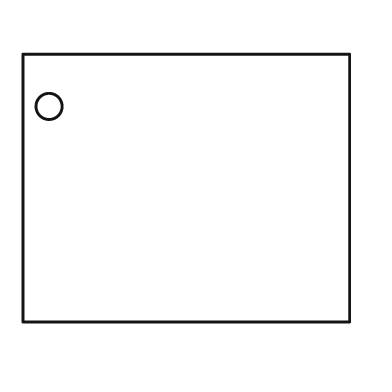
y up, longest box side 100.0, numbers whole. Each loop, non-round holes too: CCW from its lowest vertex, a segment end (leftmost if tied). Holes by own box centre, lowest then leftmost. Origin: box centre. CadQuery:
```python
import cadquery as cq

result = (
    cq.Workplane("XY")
    .moveTo(-50.0, -41.0)
    .lineTo(50.0, -41.0)
    .lineTo(50.0, 41.0)
    .lineTo(-50.0, 41.0)
    .close()
    .moveTo(-42.0, 25.0)
    .circle(4.0)
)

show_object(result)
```